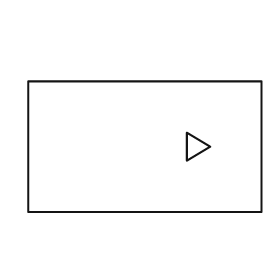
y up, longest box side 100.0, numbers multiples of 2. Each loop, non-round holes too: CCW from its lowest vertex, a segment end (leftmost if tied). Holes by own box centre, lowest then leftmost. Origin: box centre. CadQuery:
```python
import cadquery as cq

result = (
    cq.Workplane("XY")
    .moveTo(-50.0, -28.0)
    .lineTo(50.0, -28.0)
    .lineTo(50.0, 28.0)
    .lineTo(-50.0, 28.0)
    .close()
    .moveTo(18.0, -6.0)
    .lineTo(28.0, 0.0)
    .lineTo(18.0, 6.0)
    .close()
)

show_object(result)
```